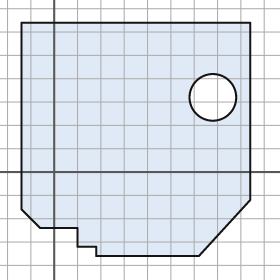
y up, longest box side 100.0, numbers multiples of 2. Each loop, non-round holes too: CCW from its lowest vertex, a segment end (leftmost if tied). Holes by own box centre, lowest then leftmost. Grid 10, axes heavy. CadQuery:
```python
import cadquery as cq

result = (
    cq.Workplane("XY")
    .moveTo(18.0, -36.0)
    .lineTo(62.0, -36.0)
    .lineTo(84.0, -12.0)
    .lineTo(84.0, 64.0)
    .lineTo(-14.0, 64.0)
    .lineTo(-14.0, -16.0)
    .lineTo(-6.0, -24.0)
    .lineTo(10.0, -24.0)
    .lineTo(10.0, -32.0)
    .lineTo(18.0, -32.0)
    .close()
    .moveTo(68.0, 32.0)
    .circle(10.0)
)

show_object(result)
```